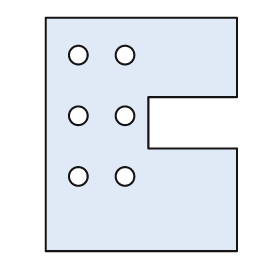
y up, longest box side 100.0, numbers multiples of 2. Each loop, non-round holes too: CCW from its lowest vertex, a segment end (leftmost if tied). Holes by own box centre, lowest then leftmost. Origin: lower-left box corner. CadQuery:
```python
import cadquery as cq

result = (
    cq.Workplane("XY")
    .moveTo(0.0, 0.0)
    .lineTo(82.0, 0.0)
    .lineTo(82.0, 44.0)
    .lineTo(44.0, 44.0)
    .lineTo(44.0, 66.0)
    .lineTo(82.0, 66.0)
    .lineTo(82.0, 100.0)
    .lineTo(0.0, 100.0)
    .close()
    .moveTo(14.0, 32.0)
    .circle(4.0)
    .moveTo(34.0, 32.0)
    .circle(4.0)
    .moveTo(14.0, 58.0)
    .circle(4.0)
    .moveTo(34.0, 58.0)
    .circle(4.0)
    .moveTo(14.0, 84.0)
    .circle(4.0)
    .moveTo(34.0, 84.0)
    .circle(4.0)
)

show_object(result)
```